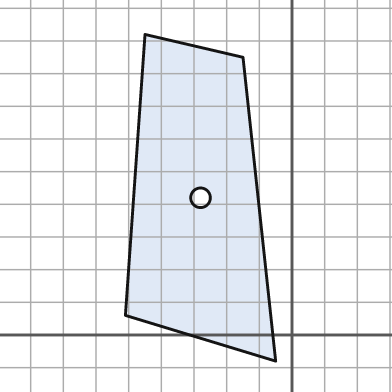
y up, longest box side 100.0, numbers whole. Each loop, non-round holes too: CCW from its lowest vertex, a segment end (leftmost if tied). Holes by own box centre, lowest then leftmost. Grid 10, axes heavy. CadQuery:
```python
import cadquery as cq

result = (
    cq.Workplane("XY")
    .moveTo(-5.0, -8.0)
    .lineTo(-15.0, 85.0)
    .lineTo(-45.0, 92.0)
    .lineTo(-51.0, 6.0)
    .close()
    .moveTo(-28.0, 42.0)
    .circle(3.0)
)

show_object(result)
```